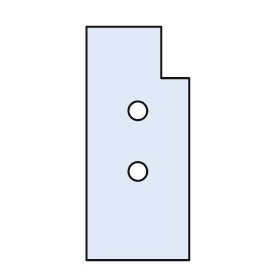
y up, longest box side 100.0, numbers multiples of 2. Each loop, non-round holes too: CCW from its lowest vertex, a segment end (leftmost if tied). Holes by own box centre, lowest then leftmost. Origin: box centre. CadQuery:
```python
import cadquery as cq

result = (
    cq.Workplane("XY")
    .moveTo(-22.0, -50.0)
    .lineTo(22.0, -50.0)
    .lineTo(22.0, 28.0)
    .lineTo(10.0, 28.0)
    .lineTo(10.0, 50.0)
    .lineTo(-22.0, 50.0)
    .close()
    .moveTo(0.0, -12.0)
    .circle(4.0)
    .moveTo(0.0, 14.0)
    .circle(4.0)
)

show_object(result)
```